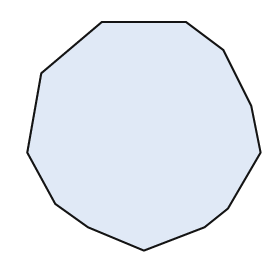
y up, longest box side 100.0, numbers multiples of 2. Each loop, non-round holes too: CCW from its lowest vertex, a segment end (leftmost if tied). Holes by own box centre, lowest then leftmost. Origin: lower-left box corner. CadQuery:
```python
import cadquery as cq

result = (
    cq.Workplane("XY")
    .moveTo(50.0, 0.0)
    .lineTo(76.0, 10.0)
    .lineTo(86.0, 18.0)
    .lineTo(100.0, 42.0)
    .lineTo(96.0, 62.0)
    .lineTo(84.0, 86.0)
    .lineTo(68.0, 98.0)
    .lineTo(32.0, 98.0)
    .lineTo(6.0, 76.0)
    .lineTo(0.0, 42.0)
    .lineTo(12.0, 20.0)
    .lineTo(26.0, 10.0)
    .close()
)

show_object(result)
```